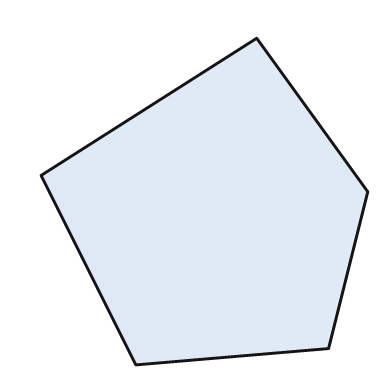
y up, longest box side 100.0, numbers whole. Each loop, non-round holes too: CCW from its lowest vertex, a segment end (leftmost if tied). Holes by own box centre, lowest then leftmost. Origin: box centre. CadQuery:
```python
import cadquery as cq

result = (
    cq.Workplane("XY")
    .moveTo(-21.0, -50.0)
    .lineTo(38.0, -45.0)
    .lineTo(50.0, 3.0)
    .lineTo(16.0, 50.0)
    .lineTo(-50.0, 8.0)
    .close()
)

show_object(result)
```